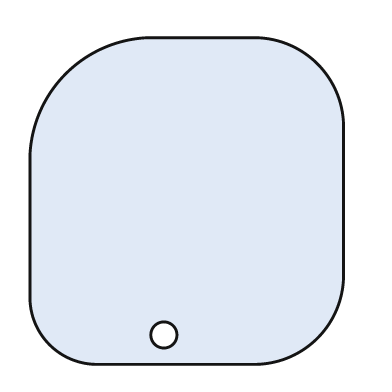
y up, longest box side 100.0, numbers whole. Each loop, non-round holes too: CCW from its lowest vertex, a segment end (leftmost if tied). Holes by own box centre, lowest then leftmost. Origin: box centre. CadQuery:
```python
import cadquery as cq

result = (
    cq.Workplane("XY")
    .moveTo(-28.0, -50.0)
    .lineTo(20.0, -50.0)
    .threePointArc((40.0, -42.0), (48.0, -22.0))
    .lineTo(48.0, 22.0)
    .threePointArc((40.0, 42.0), (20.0, 50.0))
    .lineTo(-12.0, 50.0)
    .threePointArc((-37.0, 39.0), (-48.0, 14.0))
    .lineTo(-48.0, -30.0)
    .threePointArc((-42.0, -44.0), (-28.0, -50.0))
    .close()
    .moveTo(-7.0, -41.0)
    .circle(4.0)
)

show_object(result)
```